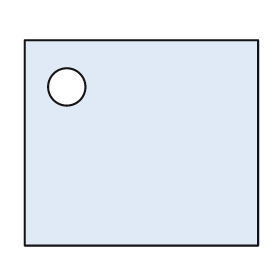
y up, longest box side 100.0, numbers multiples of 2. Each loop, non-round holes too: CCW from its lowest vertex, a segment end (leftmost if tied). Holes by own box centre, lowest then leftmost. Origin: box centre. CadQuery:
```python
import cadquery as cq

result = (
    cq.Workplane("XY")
    .moveTo(-50.0, -44.0)
    .lineTo(50.0, -44.0)
    .lineTo(50.0, 44.0)
    .lineTo(-50.0, 44.0)
    .close()
    .moveTo(-32.0, 24.0)
    .circle(8.0)
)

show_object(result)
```